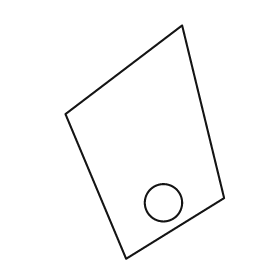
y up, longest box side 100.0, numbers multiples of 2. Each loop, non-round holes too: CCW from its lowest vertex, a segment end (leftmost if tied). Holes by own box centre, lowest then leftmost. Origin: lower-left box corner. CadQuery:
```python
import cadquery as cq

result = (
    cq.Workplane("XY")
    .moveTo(26.0, 0.0)
    .lineTo(68.0, 26.0)
    .lineTo(50.0, 100.0)
    .lineTo(0.0, 62.0)
    .close()
    .moveTo(42.0, 24.0)
    .circle(8.0)
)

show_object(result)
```